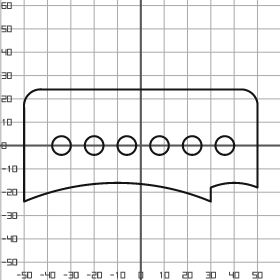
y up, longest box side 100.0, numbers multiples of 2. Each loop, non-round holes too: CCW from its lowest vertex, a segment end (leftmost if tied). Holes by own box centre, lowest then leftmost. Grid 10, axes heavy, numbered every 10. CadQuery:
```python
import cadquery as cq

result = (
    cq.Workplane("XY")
    .moveTo(-50.0, -24.0)
    .threePointArc((-10.0, -16.0), (30.0, -24.0))
    .lineTo(30.0, -18.0)
    .threePointArc((40.0, -16.0), (50.0, -18.0))
    .lineTo(50.0, 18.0)
    .threePointArc((48.0, 22.0), (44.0, 24.0))
    .lineTo(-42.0, 24.0)
    .threePointArc((-48.0, 22.0), (-50.0, 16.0))
    .close()
    .moveTo(-34.0, 0.0)
    .circle(4.0)
    .moveTo(-20.0, 0.0)
    .circle(4.0)
    .moveTo(-6.0, 0.0)
    .circle(4.0)
    .moveTo(8.0, 0.0)
    .circle(4.0)
    .moveTo(22.0, 0.0)
    .circle(4.0)
    .moveTo(36.0, 0.0)
    .circle(4.0)
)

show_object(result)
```